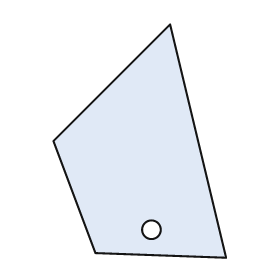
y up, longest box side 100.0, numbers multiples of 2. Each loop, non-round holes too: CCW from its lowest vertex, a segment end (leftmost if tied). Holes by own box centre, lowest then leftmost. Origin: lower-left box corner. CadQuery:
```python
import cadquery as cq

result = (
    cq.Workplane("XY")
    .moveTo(74.0, 0.0)
    .lineTo(50.0, 100.0)
    .lineTo(0.0, 50.0)
    .lineTo(18.0, 2.0)
    .close()
    .moveTo(42.0, 12.0)
    .circle(4.0)
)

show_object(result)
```